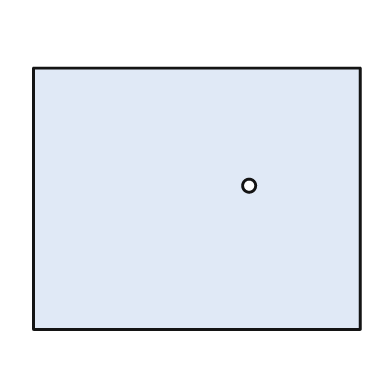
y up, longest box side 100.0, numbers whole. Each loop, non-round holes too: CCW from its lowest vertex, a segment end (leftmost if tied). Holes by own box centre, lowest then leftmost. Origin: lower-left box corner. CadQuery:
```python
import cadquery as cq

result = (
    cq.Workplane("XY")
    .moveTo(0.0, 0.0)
    .lineTo(100.0, 0.0)
    .lineTo(100.0, 80.0)
    .lineTo(0.0, 80.0)
    .close()
    .moveTo(66.0, 44.0)
    .circle(2.0)
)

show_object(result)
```